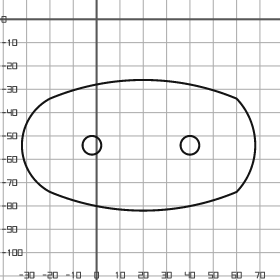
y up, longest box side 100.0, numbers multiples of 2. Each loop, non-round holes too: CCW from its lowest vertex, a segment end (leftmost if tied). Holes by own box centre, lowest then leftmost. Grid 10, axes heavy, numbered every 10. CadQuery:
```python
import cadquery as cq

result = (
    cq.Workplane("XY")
    .moveTo(-20.0, -74.0)
    .threePointArc((20.0, -82.0), (60.0, -74.0))
    .threePointArc((68.0, -54.0), (60.0, -34.0))
    .threePointArc((20.0, -26.0), (-20.0, -34.0))
    .threePointArc((-32.0, -54.0), (-20.0, -74.0))
    .close()
    .moveTo(-2.0, -54.0)
    .circle(4.0)
    .moveTo(40.0, -54.0)
    .circle(4.0)
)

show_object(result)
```